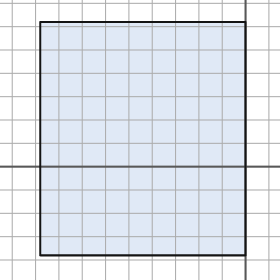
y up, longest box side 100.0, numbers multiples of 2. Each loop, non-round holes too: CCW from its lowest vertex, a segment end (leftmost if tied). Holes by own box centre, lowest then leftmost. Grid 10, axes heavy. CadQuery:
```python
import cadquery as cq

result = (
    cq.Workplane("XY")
    .moveTo(-88.0, -38.0)
    .lineTo(0.0, -38.0)
    .lineTo(0.0, 62.0)
    .lineTo(-88.0, 62.0)
    .close()
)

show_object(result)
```